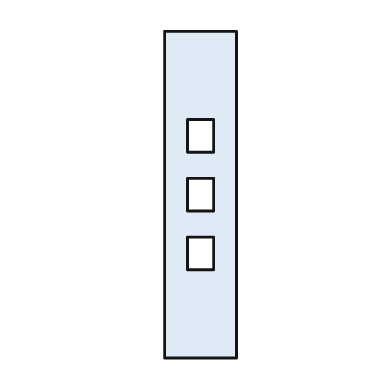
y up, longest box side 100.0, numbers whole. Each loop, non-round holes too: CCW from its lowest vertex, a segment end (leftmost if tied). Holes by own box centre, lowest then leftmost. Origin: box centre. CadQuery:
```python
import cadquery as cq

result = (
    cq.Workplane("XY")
    .moveTo(-11.0, -50.0)
    .lineTo(11.0, -50.0)
    .lineTo(11.0, 50.0)
    .lineTo(-11.0, 50.0)
    .close()
    .moveTo(-4.0, -23.0)
    .lineTo(4.0, -23.0)
    .lineTo(4.0, -13.0)
    .lineTo(-4.0, -13.0)
    .close()
    .moveTo(-4.0, -5.0)
    .lineTo(4.0, -5.0)
    .lineTo(4.0, 5.0)
    .lineTo(-4.0, 5.0)
    .close()
    .moveTo(-4.0, 13.0)
    .lineTo(4.0, 13.0)
    .lineTo(4.0, 23.0)
    .lineTo(-4.0, 23.0)
    .close()
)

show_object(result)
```